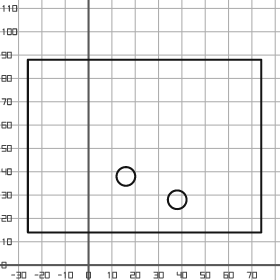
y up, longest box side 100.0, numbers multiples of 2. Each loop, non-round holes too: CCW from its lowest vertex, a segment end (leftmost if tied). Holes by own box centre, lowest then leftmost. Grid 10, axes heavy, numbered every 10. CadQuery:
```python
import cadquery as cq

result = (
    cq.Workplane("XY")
    .moveTo(-26.0, 14.0)
    .lineTo(74.0, 14.0)
    .lineTo(74.0, 88.0)
    .lineTo(-26.0, 88.0)
    .close()
    .moveTo(38.0, 28.0)
    .circle(4.0)
    .moveTo(16.0, 38.0)
    .circle(4.0)
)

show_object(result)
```